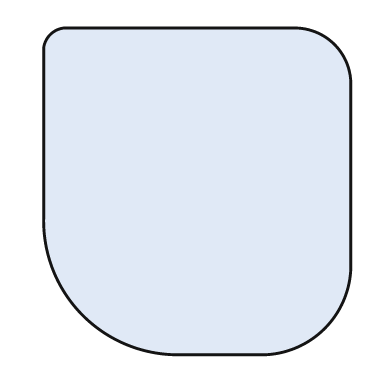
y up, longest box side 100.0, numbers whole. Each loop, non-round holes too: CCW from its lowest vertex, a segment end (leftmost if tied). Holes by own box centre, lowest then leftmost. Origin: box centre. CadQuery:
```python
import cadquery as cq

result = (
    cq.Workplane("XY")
    .moveTo(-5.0, -50.0)
    .lineTo(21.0, -50.0)
    .threePointArc((39.0, -42.0), (47.0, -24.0))
    .lineTo(47.0, 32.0)
    .threePointArc((42.0, 45.0), (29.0, 50.0))
    .lineTo(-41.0, 50.0)
    .threePointArc((-45.0, 48.0), (-47.0, 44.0))
    .lineTo(-47.0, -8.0)
    .threePointArc((-35.0, -38.0), (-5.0, -50.0))
    .close()
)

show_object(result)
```